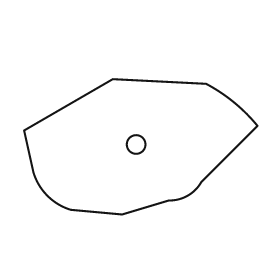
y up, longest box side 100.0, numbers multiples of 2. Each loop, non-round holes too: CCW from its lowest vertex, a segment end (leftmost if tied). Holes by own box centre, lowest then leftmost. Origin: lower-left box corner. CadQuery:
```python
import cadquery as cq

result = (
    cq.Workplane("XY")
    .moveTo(42.0, 0.0)
    .lineTo(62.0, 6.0)
    .threePointArc((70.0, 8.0), (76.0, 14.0))
    .lineTo(100.0, 38.0)
    .threePointArc((90.0, 48.0), (78.0, 56.0))
    .lineTo(38.0, 58.0)
    .lineTo(0.0, 36.0)
    .lineTo(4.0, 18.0)
    .threePointArc((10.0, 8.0), (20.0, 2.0))
    .close()
    .moveTo(48.0, 30.0)
    .circle(4.0)
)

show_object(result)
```